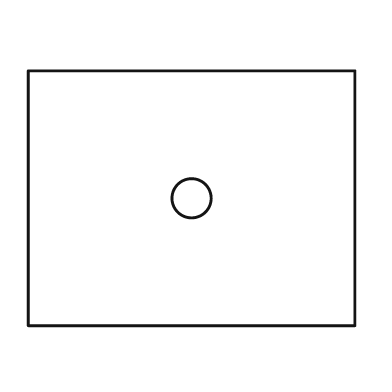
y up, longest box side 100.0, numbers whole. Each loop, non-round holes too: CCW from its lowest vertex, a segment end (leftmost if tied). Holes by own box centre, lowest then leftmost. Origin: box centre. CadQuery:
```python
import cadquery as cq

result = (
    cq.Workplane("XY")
    .moveTo(-50.0, -39.0)
    .lineTo(50.0, -39.0)
    .lineTo(50.0, 39.0)
    .lineTo(-50.0, 39.0)
    .close()
    .moveTo(0.0, 0.0)
    .circle(6.0)
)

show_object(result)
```